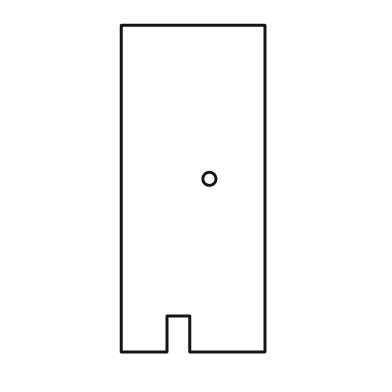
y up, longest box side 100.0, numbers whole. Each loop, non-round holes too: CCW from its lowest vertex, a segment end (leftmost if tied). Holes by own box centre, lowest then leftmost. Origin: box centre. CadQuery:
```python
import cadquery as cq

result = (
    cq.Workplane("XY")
    .moveTo(-22.0, -50.0)
    .lineTo(-8.0, -50.0)
    .lineTo(-8.0, -39.0)
    .lineTo(-1.0, -39.0)
    .lineTo(-1.0, -50.0)
    .lineTo(22.0, -50.0)
    .lineTo(22.0, 50.0)
    .lineTo(-22.0, 50.0)
    .close()
    .moveTo(5.0, 3.0)
    .circle(2.0)
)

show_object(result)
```